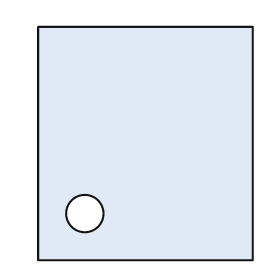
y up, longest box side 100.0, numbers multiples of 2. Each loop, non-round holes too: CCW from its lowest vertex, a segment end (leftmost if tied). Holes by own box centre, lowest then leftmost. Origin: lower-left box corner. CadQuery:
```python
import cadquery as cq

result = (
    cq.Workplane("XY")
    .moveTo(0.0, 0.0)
    .lineTo(92.0, 0.0)
    .lineTo(92.0, 100.0)
    .lineTo(0.0, 100.0)
    .close()
    .moveTo(20.0, 20.0)
    .circle(8.0)
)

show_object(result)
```